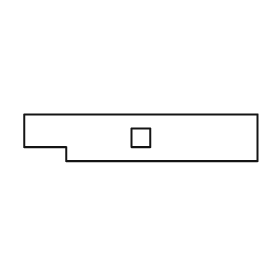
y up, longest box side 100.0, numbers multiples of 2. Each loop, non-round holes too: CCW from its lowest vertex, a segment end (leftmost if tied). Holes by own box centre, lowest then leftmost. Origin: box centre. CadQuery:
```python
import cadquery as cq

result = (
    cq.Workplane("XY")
    .moveTo(-32.0, -10.0)
    .lineTo(50.0, -10.0)
    .lineTo(50.0, 10.0)
    .lineTo(-50.0, 10.0)
    .lineTo(-50.0, -4.0)
    .lineTo(-32.0, -4.0)
    .close()
    .moveTo(-4.0, -4.0)
    .lineTo(4.0, -4.0)
    .lineTo(4.0, 4.0)
    .lineTo(-4.0, 4.0)
    .close()
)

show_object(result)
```